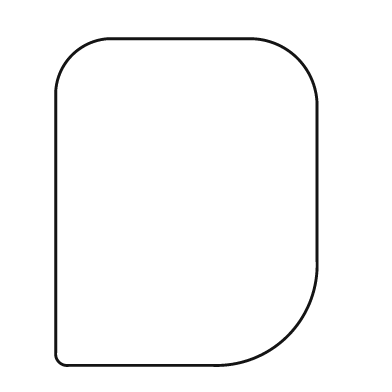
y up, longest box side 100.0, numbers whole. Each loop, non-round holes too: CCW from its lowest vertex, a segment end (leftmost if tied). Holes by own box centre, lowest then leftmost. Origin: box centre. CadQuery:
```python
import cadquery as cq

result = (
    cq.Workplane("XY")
    .moveTo(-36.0, -50.0)
    .lineTo(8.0, -50.0)
    .threePointArc((31.0, -41.0), (40.0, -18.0))
    .lineTo(40.0, 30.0)
    .threePointArc((34.0, 44.0), (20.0, 50.0))
    .lineTo(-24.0, 50.0)
    .threePointArc((-35.0, 45.0), (-40.0, 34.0))
    .lineTo(-40.0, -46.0)
    .threePointArc((-39.0, -49.0), (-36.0, -50.0))
    .close()
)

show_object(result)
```